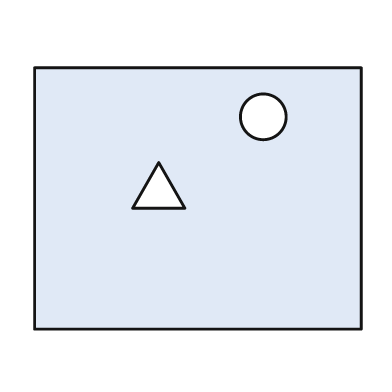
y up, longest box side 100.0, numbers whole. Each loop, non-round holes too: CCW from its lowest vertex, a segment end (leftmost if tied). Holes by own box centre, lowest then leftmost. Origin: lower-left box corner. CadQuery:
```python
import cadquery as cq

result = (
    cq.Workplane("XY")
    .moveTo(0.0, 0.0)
    .lineTo(100.0, 0.0)
    .lineTo(100.0, 80.0)
    .lineTo(0.0, 80.0)
    .close()
    .moveTo(30.0, 37.0)
    .lineTo(46.0, 37.0)
    .lineTo(38.0, 51.0)
    .close()
    .moveTo(70.0, 65.0)
    .circle(7.0)
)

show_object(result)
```